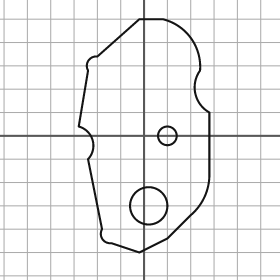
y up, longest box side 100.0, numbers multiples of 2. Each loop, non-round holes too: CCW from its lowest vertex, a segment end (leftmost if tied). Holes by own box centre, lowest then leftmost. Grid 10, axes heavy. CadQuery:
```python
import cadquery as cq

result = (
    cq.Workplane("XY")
    .moveTo(-2.0, -50.0)
    .lineTo(10.0, -44.0)
    .lineTo(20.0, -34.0)
    .threePointArc((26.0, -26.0), (28.0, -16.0))
    .lineTo(28.0, 10.0)
    .threePointArc((22.0, 18.0), (24.0, 28.0))
    .threePointArc((20.0, 42.0), (8.0, 50.0))
    .lineTo(-2.0, 50.0)
    .lineTo(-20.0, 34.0)
    .threePointArc((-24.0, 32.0), (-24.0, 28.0))
    .lineTo(-28.0, 4.0)
    .threePointArc((-22.0, -2.0), (-24.0, -10.0))
    .lineTo(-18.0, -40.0)
    .threePointArc((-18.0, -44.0), (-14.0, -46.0))
    .close()
    .moveTo(2.0, -30.0)
    .circle(8.0)
    .moveTo(10.0, 0.0)
    .circle(4.0)
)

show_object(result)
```